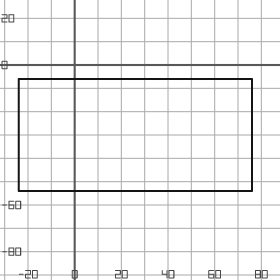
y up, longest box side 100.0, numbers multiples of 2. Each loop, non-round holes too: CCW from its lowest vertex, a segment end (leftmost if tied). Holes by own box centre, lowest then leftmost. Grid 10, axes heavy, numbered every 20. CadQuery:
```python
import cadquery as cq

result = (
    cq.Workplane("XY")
    .moveTo(-24.0, -54.0)
    .lineTo(76.0, -54.0)
    .lineTo(76.0, -6.0)
    .lineTo(-24.0, -6.0)
    .close()
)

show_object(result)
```